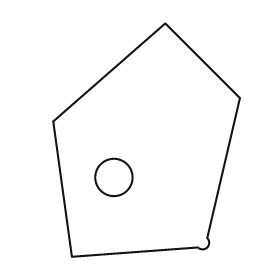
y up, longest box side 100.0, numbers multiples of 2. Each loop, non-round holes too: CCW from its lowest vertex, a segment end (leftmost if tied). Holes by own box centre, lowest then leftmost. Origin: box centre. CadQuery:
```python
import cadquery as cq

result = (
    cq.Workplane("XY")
    .moveTo(-32.0, -50.0)
    .lineTo(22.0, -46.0)
    .threePointArc((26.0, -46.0), (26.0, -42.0))
    .lineTo(40.0, 18.0)
    .lineTo(8.0, 50.0)
    .lineTo(-40.0, 8.0)
    .close()
    .moveTo(-14.0, -16.0)
    .circle(8.0)
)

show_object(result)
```